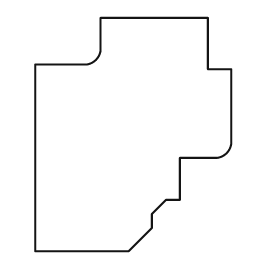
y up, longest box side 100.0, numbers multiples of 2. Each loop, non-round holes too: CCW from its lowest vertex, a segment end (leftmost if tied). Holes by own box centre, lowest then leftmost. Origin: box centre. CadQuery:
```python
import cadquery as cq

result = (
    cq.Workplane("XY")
    .moveTo(-42.0, -50.0)
    .lineTo(-2.0, -50.0)
    .lineTo(8.0, -40.0)
    .lineTo(8.0, -34.0)
    .lineTo(14.0, -28.0)
    .lineTo(20.0, -28.0)
    .lineTo(20.0, -10.0)
    .lineTo(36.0, -10.0)
    .threePointArc((40.0, -8.0), (42.0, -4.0))
    .lineTo(42.0, 28.0)
    .lineTo(32.0, 28.0)
    .lineTo(32.0, 50.0)
    .lineTo(-14.0, 50.0)
    .lineTo(-14.0, 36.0)
    .threePointArc((-16.0, 32.0), (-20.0, 30.0))
    .lineTo(-42.0, 30.0)
    .close()
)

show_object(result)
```